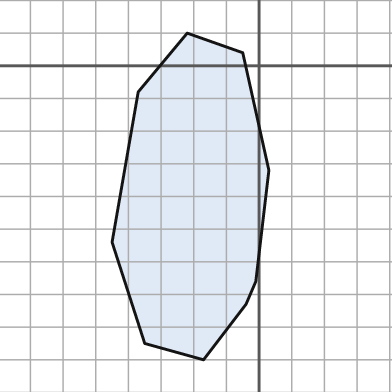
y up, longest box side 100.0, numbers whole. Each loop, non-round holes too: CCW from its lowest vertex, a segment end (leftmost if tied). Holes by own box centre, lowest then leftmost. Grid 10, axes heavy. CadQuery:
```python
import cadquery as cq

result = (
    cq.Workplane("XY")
    .moveTo(-17.0, -90.0)
    .lineTo(-4.0, -73.0)
    .lineTo(-1.0, -66.0)
    .lineTo(3.0, -32.0)
    .lineTo(-5.0, 4.0)
    .lineTo(-22.0, 10.0)
    .lineTo(-37.0, -8.0)
    .lineTo(-45.0, -54.0)
    .lineTo(-35.0, -85.0)
    .close()
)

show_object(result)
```